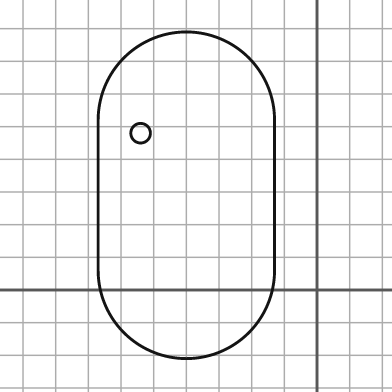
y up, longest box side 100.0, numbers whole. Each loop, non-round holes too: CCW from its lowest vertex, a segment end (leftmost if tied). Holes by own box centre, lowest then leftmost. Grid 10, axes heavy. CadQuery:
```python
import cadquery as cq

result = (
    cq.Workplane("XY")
    .moveTo(-67.0, 6.0)
    .threePointArc((-40.0, -21.0), (-13.0, 6.0))
    .lineTo(-13.0, 52.0)
    .threePointArc((-40.0, 79.0), (-67.0, 52.0))
    .close()
    .moveTo(-54.0, 48.0)
    .circle(3.0)
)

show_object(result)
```